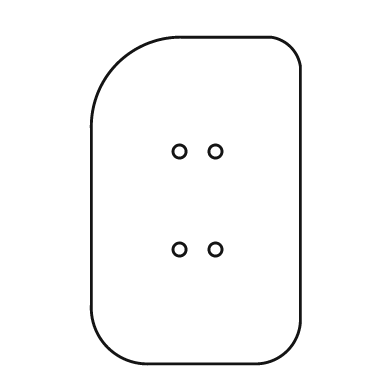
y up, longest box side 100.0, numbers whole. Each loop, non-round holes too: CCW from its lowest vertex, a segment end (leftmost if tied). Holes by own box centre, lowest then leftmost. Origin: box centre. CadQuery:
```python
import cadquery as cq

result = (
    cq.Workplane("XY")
    .moveTo(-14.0, -50.0)
    .lineTo(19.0, -50.0)
    .threePointArc((28.0, -46.0), (32.0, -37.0))
    .lineTo(32.0, 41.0)
    .threePointArc((29.0, 47.0), (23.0, 50.0))
    .lineTo(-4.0, 50.0)
    .threePointArc((-24.0, 42.0), (-32.0, 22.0))
    .lineTo(-32.0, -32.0)
    .threePointArc((-27.0, -45.0), (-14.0, -50.0))
    .close()
    .moveTo(-5.0, -15.0)
    .circle(2.0)
    .moveTo(6.0, -15.0)
    .circle(2.0)
    .moveTo(-5.0, 15.0)
    .circle(2.0)
    .moveTo(6.0, 15.0)
    .circle(2.0)
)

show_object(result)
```